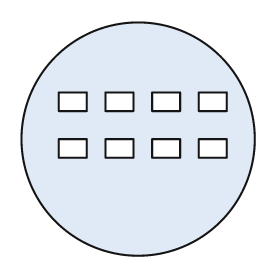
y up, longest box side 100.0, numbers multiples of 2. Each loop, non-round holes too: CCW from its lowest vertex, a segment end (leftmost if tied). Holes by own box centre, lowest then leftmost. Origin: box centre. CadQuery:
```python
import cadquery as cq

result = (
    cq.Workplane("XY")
    .moveTo(0.0, 0.0)
    .circle(50.0)
    .moveTo(-34.0, -8.0)
    .lineTo(-22.0, -8.0)
    .lineTo(-22.0, 0.0)
    .lineTo(-34.0, 0.0)
    .close()
    .moveTo(-14.0, -8.0)
    .lineTo(-2.0, -8.0)
    .lineTo(-2.0, 0.0)
    .lineTo(-14.0, 0.0)
    .close()
    .moveTo(6.0, -8.0)
    .lineTo(18.0, -8.0)
    .lineTo(18.0, 0.0)
    .lineTo(6.0, 0.0)
    .close()
    .moveTo(26.0, -8.0)
    .lineTo(38.0, -8.0)
    .lineTo(38.0, 0.0)
    .lineTo(26.0, 0.0)
    .close()
    .moveTo(-34.0, 12.0)
    .lineTo(-22.0, 12.0)
    .lineTo(-22.0, 20.0)
    .lineTo(-34.0, 20.0)
    .close()
    .moveTo(-14.0, 12.0)
    .lineTo(-2.0, 12.0)
    .lineTo(-2.0, 20.0)
    .lineTo(-14.0, 20.0)
    .close()
    .moveTo(6.0, 12.0)
    .lineTo(18.0, 12.0)
    .lineTo(18.0, 20.0)
    .lineTo(6.0, 20.0)
    .close()
    .moveTo(26.0, 12.0)
    .lineTo(38.0, 12.0)
    .lineTo(38.0, 20.0)
    .lineTo(26.0, 20.0)
    .close()
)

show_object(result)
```